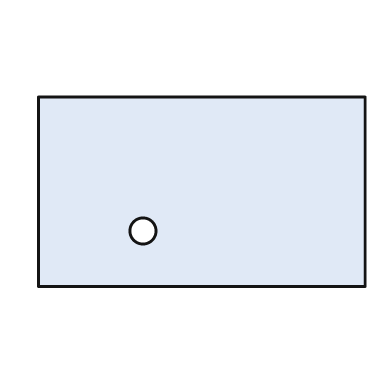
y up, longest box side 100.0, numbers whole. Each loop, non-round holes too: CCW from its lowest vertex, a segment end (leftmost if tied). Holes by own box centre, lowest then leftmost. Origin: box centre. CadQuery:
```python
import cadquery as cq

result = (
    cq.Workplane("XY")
    .moveTo(-50.0, -29.0)
    .lineTo(50.0, -29.0)
    .lineTo(50.0, 29.0)
    .lineTo(-50.0, 29.0)
    .close()
    .moveTo(-18.0, -12.0)
    .circle(4.0)
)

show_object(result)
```